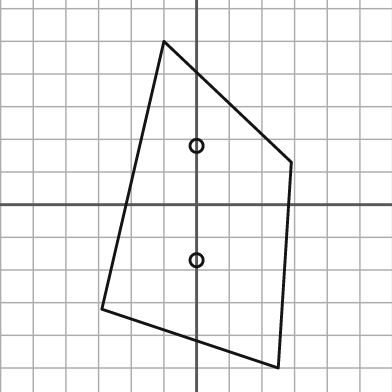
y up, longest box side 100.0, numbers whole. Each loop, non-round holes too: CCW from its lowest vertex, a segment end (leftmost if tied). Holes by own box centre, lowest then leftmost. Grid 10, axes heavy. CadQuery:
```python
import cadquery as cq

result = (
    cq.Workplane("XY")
    .moveTo(25.0, -50.0)
    .lineTo(29.0, 13.0)
    .lineTo(-10.0, 50.0)
    .lineTo(-29.0, -32.0)
    .close()
    .moveTo(0.0, -17.0)
    .circle(2.0)
    .moveTo(0.0, 18.0)
    .circle(2.0)
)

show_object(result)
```